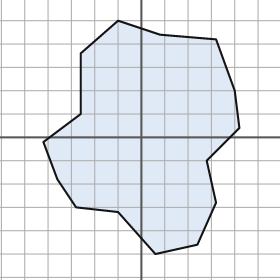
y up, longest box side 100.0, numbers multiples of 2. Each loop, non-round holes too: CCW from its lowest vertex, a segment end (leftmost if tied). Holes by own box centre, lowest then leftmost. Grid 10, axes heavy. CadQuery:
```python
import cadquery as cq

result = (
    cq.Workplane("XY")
    .moveTo(6.0, -50.0)
    .lineTo(24.0, -46.0)
    .lineTo(32.0, -28.0)
    .lineTo(28.0, -10.0)
    .lineTo(42.0, 4.0)
    .lineTo(40.0, 20.0)
    .lineTo(32.0, 42.0)
    .lineTo(8.0, 44.0)
    .lineTo(-10.0, 50.0)
    .lineTo(-26.0, 36.0)
    .lineTo(-26.0, 10.0)
    .lineTo(-42.0, -2.0)
    .lineTo(-36.0, -18.0)
    .lineTo(-28.0, -30.0)
    .lineTo(-10.0, -32.0)
    .close()
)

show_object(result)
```